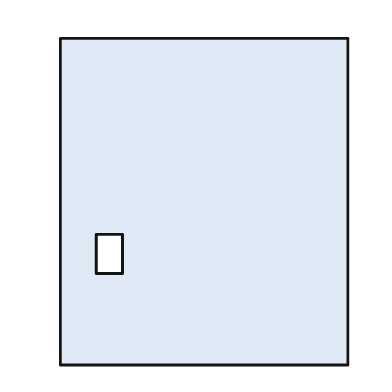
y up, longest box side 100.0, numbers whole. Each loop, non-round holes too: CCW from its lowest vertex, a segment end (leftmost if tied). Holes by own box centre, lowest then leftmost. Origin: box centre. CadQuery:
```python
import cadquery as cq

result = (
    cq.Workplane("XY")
    .moveTo(-44.0, -50.0)
    .lineTo(44.0, -50.0)
    .lineTo(44.0, 50.0)
    .lineTo(-44.0, 50.0)
    .close()
    .moveTo(-33.0, -22.0)
    .lineTo(-25.0, -22.0)
    .lineTo(-25.0, -10.0)
    .lineTo(-33.0, -10.0)
    .close()
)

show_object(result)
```